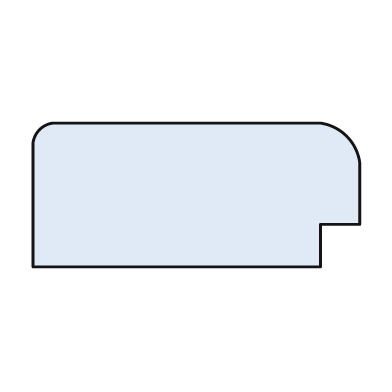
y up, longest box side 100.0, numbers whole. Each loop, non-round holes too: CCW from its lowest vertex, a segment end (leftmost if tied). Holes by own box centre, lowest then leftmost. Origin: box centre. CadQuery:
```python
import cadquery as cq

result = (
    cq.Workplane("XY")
    .moveTo(-50.0, -22.0)
    .lineTo(38.0, -22.0)
    .lineTo(38.0, -9.0)
    .lineTo(50.0, -9.0)
    .lineTo(50.0, 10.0)
    .threePointArc((46.0, 18.0), (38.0, 22.0))
    .lineTo(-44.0, 22.0)
    .threePointArc((-48.0, 20.0), (-50.0, 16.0))
    .close()
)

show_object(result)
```